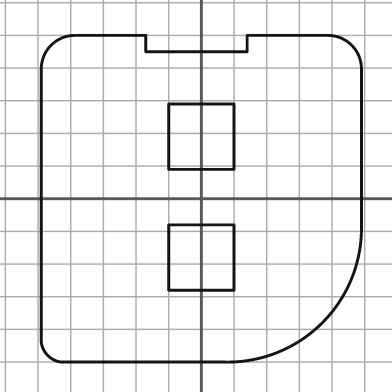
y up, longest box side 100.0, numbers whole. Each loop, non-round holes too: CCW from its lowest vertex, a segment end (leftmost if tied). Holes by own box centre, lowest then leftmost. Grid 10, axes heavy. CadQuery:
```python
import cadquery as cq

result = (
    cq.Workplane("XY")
    .moveTo(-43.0, -50.0)
    .lineTo(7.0, -50.0)
    .threePointArc((37.0, -38.0), (49.0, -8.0))
    .lineTo(49.0, 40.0)
    .threePointArc((46.0, 47.0), (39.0, 50.0))
    .lineTo(14.0, 50.0)
    .lineTo(14.0, 45.0)
    .lineTo(-17.0, 45.0)
    .lineTo(-17.0, 50.0)
    .lineTo(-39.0, 50.0)
    .threePointArc((-46.0, 47.0), (-49.0, 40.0))
    .lineTo(-49.0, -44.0)
    .threePointArc((-47.0, -48.0), (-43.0, -50.0))
    .close()
    .moveTo(-10.0, -28.0)
    .lineTo(10.0, -28.0)
    .lineTo(10.0, -8.0)
    .lineTo(-10.0, -8.0)
    .close()
    .moveTo(-10.0, 9.0)
    .lineTo(10.0, 9.0)
    .lineTo(10.0, 29.0)
    .lineTo(-10.0, 29.0)
    .close()
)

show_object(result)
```